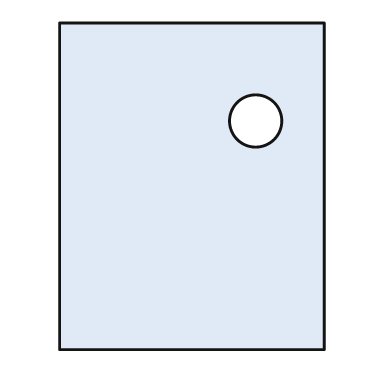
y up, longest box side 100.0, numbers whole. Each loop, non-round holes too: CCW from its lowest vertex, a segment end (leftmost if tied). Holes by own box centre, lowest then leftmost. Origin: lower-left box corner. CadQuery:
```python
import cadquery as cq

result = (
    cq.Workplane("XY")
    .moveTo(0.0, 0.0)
    .lineTo(81.0, 0.0)
    .lineTo(81.0, 100.0)
    .lineTo(0.0, 100.0)
    .close()
    .moveTo(60.0, 70.0)
    .circle(8.0)
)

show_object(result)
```